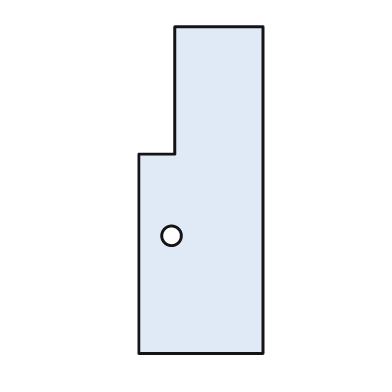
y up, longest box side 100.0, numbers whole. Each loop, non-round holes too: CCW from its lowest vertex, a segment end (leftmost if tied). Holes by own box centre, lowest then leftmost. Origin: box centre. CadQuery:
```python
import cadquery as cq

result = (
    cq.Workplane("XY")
    .moveTo(-19.0, -50.0)
    .lineTo(19.0, -50.0)
    .lineTo(19.0, 50.0)
    .lineTo(-8.0, 50.0)
    .lineTo(-8.0, 11.0)
    .lineTo(-19.0, 11.0)
    .close()
    .moveTo(-9.0, -14.0)
    .circle(3.0)
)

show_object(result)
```